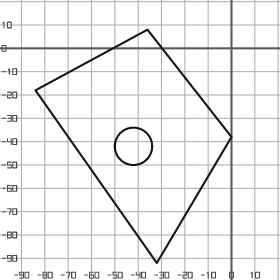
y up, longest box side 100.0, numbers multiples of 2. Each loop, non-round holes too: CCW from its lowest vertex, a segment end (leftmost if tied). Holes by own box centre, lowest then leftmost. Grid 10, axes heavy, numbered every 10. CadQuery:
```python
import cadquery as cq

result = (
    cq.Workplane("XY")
    .moveTo(-32.0, -92.0)
    .lineTo(0.0, -38.0)
    .lineTo(-36.0, 8.0)
    .lineTo(-84.0, -18.0)
    .close()
    .moveTo(-42.0, -42.0)
    .circle(8.0)
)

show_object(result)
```